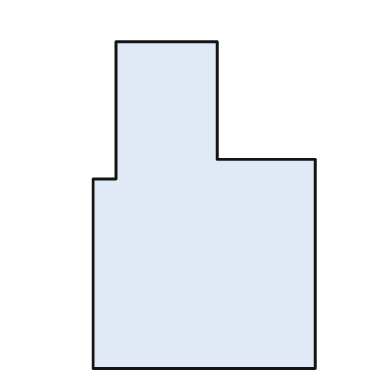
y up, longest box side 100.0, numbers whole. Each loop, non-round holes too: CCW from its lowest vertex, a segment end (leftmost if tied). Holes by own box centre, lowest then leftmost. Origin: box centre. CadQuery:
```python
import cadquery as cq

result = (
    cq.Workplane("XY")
    .moveTo(-34.0, -50.0)
    .lineTo(34.0, -50.0)
    .lineTo(34.0, 14.0)
    .lineTo(4.0, 14.0)
    .lineTo(4.0, 50.0)
    .lineTo(-27.0, 50.0)
    .lineTo(-27.0, 8.0)
    .lineTo(-34.0, 8.0)
    .close()
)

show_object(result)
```